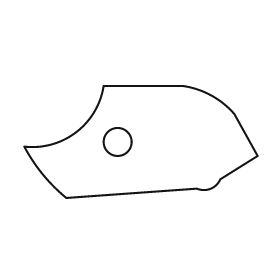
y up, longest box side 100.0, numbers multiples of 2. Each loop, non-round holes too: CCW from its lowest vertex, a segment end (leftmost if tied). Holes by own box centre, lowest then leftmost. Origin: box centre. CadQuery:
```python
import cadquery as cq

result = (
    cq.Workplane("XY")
    .moveTo(-32.0, -24.0)
    .lineTo(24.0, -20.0)
    .threePointArc((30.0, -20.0), (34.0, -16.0))
    .lineTo(50.0, -6.0)
    .lineTo(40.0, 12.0)
    .threePointArc((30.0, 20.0), (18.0, 24.0))
    .lineTo(-16.0, 24.0)
    .threePointArc((-28.0, 4.0), (-50.0, -2.0))
    .threePointArc((-42.0, -14.0), (-32.0, -24.0))
    .close()
    .moveTo(-10.0, 0.0)
    .circle(6.0)
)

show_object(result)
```